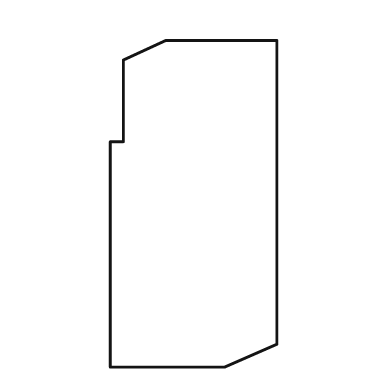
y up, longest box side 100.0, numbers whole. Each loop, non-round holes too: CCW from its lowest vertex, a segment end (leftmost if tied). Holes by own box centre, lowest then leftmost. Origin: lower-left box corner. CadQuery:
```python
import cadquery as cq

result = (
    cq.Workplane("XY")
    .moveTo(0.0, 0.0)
    .lineTo(35.0, 0.0)
    .lineTo(51.0, 7.0)
    .lineTo(51.0, 100.0)
    .lineTo(17.0, 100.0)
    .lineTo(4.0, 94.0)
    .lineTo(4.0, 69.0)
    .lineTo(0.0, 69.0)
    .close()
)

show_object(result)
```